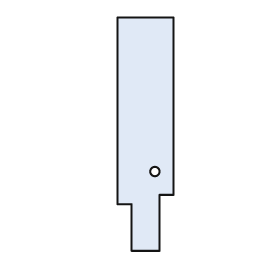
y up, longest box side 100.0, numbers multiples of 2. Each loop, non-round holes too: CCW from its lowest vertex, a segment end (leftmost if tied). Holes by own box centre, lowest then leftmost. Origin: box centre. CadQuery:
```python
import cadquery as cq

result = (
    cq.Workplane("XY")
    .moveTo(-6.0, -50.0)
    .lineTo(6.0, -50.0)
    .lineTo(6.0, -26.0)
    .lineTo(12.0, -26.0)
    .lineTo(12.0, 50.0)
    .lineTo(-12.0, 50.0)
    .lineTo(-12.0, -30.0)
    .lineTo(-6.0, -30.0)
    .close()
    .moveTo(4.0, -16.0)
    .circle(2.0)
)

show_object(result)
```